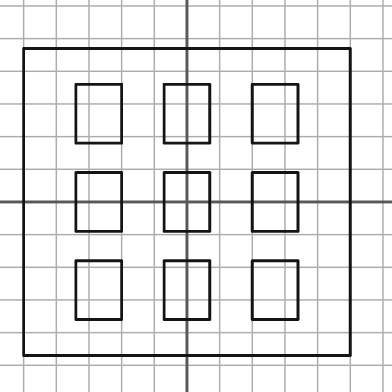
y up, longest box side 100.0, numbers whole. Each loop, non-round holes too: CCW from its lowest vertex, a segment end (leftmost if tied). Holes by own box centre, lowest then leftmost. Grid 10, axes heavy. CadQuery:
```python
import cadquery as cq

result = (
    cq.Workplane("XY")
    .moveTo(-50.0, -47.0)
    .lineTo(50.0, -47.0)
    .lineTo(50.0, 47.0)
    .lineTo(-50.0, 47.0)
    .close()
    .moveTo(-34.0, -36.0)
    .lineTo(-20.0, -36.0)
    .lineTo(-20.0, -18.0)
    .lineTo(-34.0, -18.0)
    .close()
    .moveTo(-7.0, -36.0)
    .lineTo(7.0, -36.0)
    .lineTo(7.0, -18.0)
    .lineTo(-7.0, -18.0)
    .close()
    .moveTo(20.0, -36.0)
    .lineTo(34.0, -36.0)
    .lineTo(34.0, -18.0)
    .lineTo(20.0, -18.0)
    .close()
    .moveTo(-34.0, -9.0)
    .lineTo(-20.0, -9.0)
    .lineTo(-20.0, 9.0)
    .lineTo(-34.0, 9.0)
    .close()
    .moveTo(-7.0, -9.0)
    .lineTo(7.0, -9.0)
    .lineTo(7.0, 9.0)
    .lineTo(-7.0, 9.0)
    .close()
    .moveTo(20.0, -9.0)
    .lineTo(34.0, -9.0)
    .lineTo(34.0, 9.0)
    .lineTo(20.0, 9.0)
    .close()
    .moveTo(-34.0, 18.0)
    .lineTo(-20.0, 18.0)
    .lineTo(-20.0, 36.0)
    .lineTo(-34.0, 36.0)
    .close()
    .moveTo(-7.0, 18.0)
    .lineTo(7.0, 18.0)
    .lineTo(7.0, 36.0)
    .lineTo(-7.0, 36.0)
    .close()
    .moveTo(20.0, 18.0)
    .lineTo(34.0, 18.0)
    .lineTo(34.0, 36.0)
    .lineTo(20.0, 36.0)
    .close()
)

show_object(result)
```